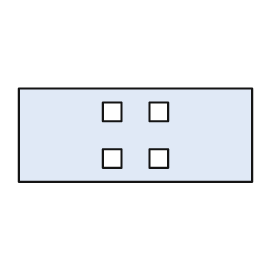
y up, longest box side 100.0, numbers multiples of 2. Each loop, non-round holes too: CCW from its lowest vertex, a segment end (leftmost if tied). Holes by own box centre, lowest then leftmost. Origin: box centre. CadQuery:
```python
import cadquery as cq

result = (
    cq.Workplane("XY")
    .moveTo(-50.0, -20.0)
    .lineTo(50.0, -20.0)
    .lineTo(50.0, 20.0)
    .lineTo(-50.0, 20.0)
    .close()
    .moveTo(-14.0, -14.0)
    .lineTo(-6.0, -14.0)
    .lineTo(-6.0, -6.0)
    .lineTo(-14.0, -6.0)
    .close()
    .moveTo(6.0, -14.0)
    .lineTo(14.0, -14.0)
    .lineTo(14.0, -6.0)
    .lineTo(6.0, -6.0)
    .close()
    .moveTo(-14.0, 6.0)
    .lineTo(-6.0, 6.0)
    .lineTo(-6.0, 14.0)
    .lineTo(-14.0, 14.0)
    .close()
    .moveTo(6.0, 6.0)
    .lineTo(14.0, 6.0)
    .lineTo(14.0, 14.0)
    .lineTo(6.0, 14.0)
    .close()
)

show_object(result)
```